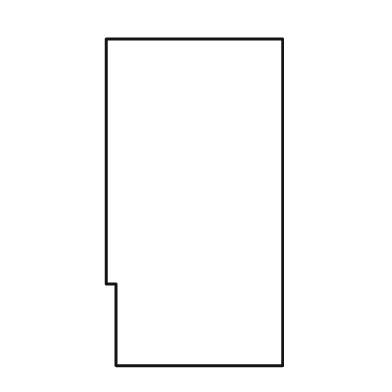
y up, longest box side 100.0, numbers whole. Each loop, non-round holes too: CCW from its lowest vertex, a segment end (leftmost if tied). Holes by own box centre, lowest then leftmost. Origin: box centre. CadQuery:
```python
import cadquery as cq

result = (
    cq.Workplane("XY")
    .moveTo(-24.0, -50.0)
    .lineTo(27.0, -50.0)
    .lineTo(27.0, 50.0)
    .lineTo(-27.0, 50.0)
    .lineTo(-27.0, -25.0)
    .lineTo(-24.0, -25.0)
    .close()
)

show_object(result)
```